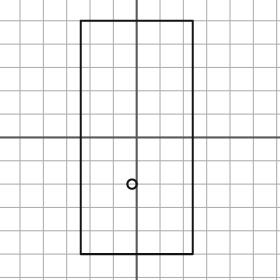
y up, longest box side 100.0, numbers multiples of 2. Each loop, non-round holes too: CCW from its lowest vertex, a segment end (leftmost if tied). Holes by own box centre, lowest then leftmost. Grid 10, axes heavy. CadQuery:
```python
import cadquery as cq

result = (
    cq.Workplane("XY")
    .moveTo(-24.0, -50.0)
    .lineTo(24.0, -50.0)
    .lineTo(24.0, 50.0)
    .lineTo(-24.0, 50.0)
    .close()
    .moveTo(-2.0, -20.0)
    .circle(2.0)
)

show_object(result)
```